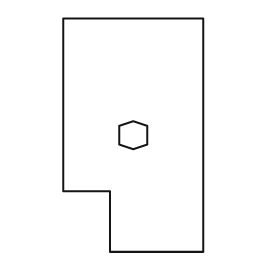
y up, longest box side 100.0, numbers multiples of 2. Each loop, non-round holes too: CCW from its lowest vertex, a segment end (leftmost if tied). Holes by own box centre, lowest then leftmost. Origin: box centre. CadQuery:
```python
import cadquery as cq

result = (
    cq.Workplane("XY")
    .moveTo(-10.0, -50.0)
    .lineTo(30.0, -50.0)
    .lineTo(30.0, 50.0)
    .lineTo(-30.0, 50.0)
    .lineTo(-30.0, -24.0)
    .lineTo(-10.0, -24.0)
    .close()
    .moveTo(0.0, -6.0)
    .lineTo(6.0, -4.0)
    .lineTo(6.0, 4.0)
    .lineTo(0.0, 6.0)
    .lineTo(-6.0, 4.0)
    .lineTo(-6.0, -4.0)
    .close()
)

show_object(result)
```